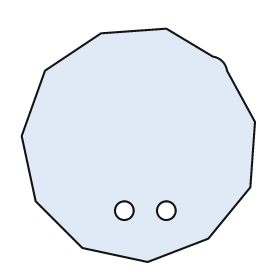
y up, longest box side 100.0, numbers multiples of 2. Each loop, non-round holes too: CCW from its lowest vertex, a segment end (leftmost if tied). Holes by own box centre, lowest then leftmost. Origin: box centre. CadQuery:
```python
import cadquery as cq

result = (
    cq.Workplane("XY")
    .moveTo(4.0, -50.0)
    .lineTo(30.0, -40.0)
    .lineTo(48.0, -18.0)
    .lineTo(50.0, 10.0)
    .lineTo(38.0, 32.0)
    .threePointArc((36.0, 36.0), (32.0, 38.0))
    .lineTo(12.0, 50.0)
    .lineTo(-16.0, 48.0)
    .lineTo(-40.0, 32.0)
    .lineTo(-50.0, 4.0)
    .lineTo(-44.0, -24.0)
    .lineTo(-24.0, -44.0)
    .close()
    .moveTo(-6.0, -28.0)
    .circle(4.0)
    .moveTo(12.0, -28.0)
    .circle(4.0)
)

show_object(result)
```